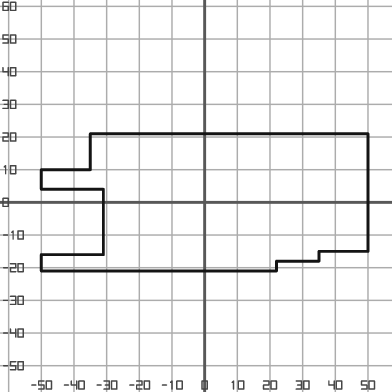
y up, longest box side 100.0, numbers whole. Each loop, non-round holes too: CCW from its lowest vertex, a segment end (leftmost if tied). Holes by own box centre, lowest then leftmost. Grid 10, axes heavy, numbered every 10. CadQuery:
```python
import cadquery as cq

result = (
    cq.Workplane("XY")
    .moveTo(-50.0, -21.0)
    .lineTo(22.0, -21.0)
    .lineTo(22.0, -18.0)
    .lineTo(35.0, -18.0)
    .lineTo(35.0, -15.0)
    .lineTo(50.0, -15.0)
    .lineTo(50.0, 21.0)
    .lineTo(-35.0, 21.0)
    .lineTo(-35.0, 10.0)
    .lineTo(-50.0, 10.0)
    .lineTo(-50.0, 4.0)
    .lineTo(-31.0, 4.0)
    .lineTo(-31.0, -16.0)
    .lineTo(-50.0, -16.0)
    .close()
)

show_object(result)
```